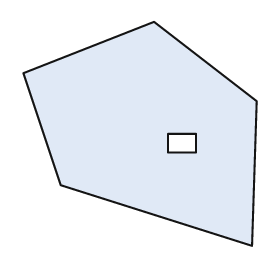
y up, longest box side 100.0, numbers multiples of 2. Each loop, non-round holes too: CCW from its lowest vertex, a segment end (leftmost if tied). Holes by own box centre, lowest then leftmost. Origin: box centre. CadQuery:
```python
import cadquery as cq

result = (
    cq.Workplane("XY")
    .moveTo(48.0, -48.0)
    .lineTo(50.0, 14.0)
    .lineTo(6.0, 48.0)
    .lineTo(-50.0, 26.0)
    .lineTo(-34.0, -22.0)
    .close()
    .moveTo(12.0, -8.0)
    .lineTo(24.0, -8.0)
    .lineTo(24.0, 0.0)
    .lineTo(12.0, 0.0)
    .close()
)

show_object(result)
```